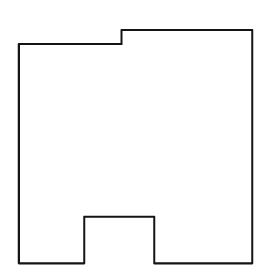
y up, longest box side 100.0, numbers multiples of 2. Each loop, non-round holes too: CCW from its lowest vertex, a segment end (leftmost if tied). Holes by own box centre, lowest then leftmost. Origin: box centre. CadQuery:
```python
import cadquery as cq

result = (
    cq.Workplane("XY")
    .moveTo(-50.0, -50.0)
    .lineTo(-22.0, -50.0)
    .lineTo(-22.0, -30.0)
    .lineTo(8.0, -30.0)
    .lineTo(8.0, -50.0)
    .lineTo(50.0, -50.0)
    .lineTo(50.0, 50.0)
    .lineTo(-6.0, 50.0)
    .lineTo(-6.0, 44.0)
    .lineTo(-50.0, 44.0)
    .close()
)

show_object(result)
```